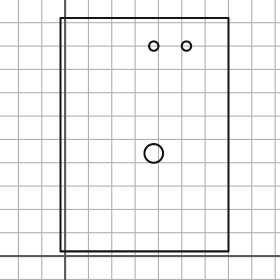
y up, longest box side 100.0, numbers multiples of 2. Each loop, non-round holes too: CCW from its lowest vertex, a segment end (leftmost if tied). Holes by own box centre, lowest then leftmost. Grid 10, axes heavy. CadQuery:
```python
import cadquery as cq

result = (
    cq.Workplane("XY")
    .moveTo(-2.0, 2.0)
    .lineTo(70.0, 2.0)
    .lineTo(70.0, 102.0)
    .lineTo(-2.0, 102.0)
    .close()
    .moveTo(38.0, 44.0)
    .circle(4.0)
    .moveTo(38.0, 90.0)
    .circle(2.0)
    .moveTo(52.0, 90.0)
    .circle(2.0)
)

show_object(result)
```